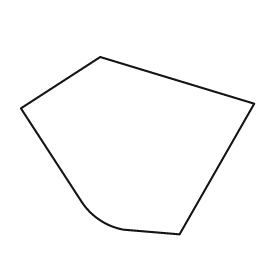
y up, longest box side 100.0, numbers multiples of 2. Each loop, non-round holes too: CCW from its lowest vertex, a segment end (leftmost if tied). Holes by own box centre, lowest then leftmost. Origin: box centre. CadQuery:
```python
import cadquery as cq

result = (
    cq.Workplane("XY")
    .moveTo(18.0, -38.0)
    .lineTo(50.0, 18.0)
    .lineTo(-16.0, 38.0)
    .lineTo(-50.0, 16.0)
    .lineTo(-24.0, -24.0)
    .threePointArc((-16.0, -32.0), (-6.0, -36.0))
    .close()
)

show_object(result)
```